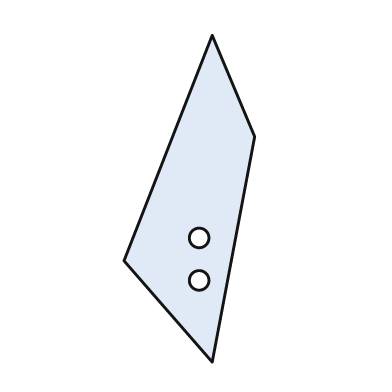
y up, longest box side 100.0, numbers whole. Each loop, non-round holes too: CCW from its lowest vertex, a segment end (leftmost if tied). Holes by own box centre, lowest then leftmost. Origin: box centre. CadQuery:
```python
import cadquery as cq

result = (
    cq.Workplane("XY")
    .moveTo(7.0, -50.0)
    .lineTo(20.0, 19.0)
    .lineTo(7.0, 50.0)
    .lineTo(-20.0, -19.0)
    .close()
    .moveTo(3.0, -25.0)
    .circle(3.0)
    .moveTo(3.0, -12.0)
    .circle(3.0)
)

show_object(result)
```